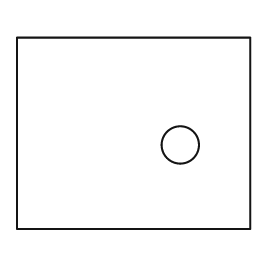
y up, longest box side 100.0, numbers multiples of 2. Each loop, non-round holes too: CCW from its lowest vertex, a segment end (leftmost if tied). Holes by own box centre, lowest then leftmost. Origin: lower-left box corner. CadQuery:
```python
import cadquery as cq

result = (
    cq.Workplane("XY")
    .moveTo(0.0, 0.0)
    .lineTo(100.0, 0.0)
    .lineTo(100.0, 82.0)
    .lineTo(0.0, 82.0)
    .close()
    .moveTo(70.0, 36.0)
    .circle(8.0)
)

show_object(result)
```